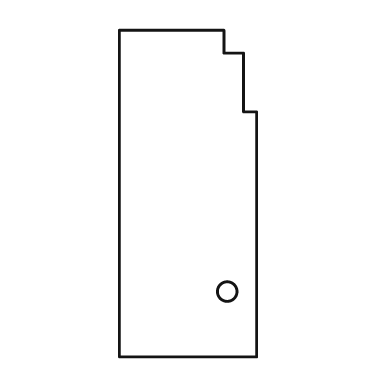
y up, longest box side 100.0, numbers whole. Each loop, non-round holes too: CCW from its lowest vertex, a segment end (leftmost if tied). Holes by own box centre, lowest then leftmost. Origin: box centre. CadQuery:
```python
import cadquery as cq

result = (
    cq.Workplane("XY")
    .moveTo(-21.0, -50.0)
    .lineTo(21.0, -50.0)
    .lineTo(21.0, 25.0)
    .lineTo(17.0, 25.0)
    .lineTo(17.0, 43.0)
    .lineTo(11.0, 43.0)
    .lineTo(11.0, 50.0)
    .lineTo(-21.0, 50.0)
    .close()
    .moveTo(12.0, -30.0)
    .circle(3.0)
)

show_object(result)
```